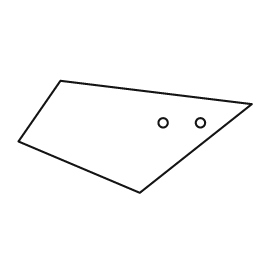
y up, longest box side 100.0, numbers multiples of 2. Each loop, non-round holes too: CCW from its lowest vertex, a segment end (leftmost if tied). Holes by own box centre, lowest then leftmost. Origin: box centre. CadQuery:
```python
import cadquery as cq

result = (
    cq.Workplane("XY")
    .moveTo(2.0, -24.0)
    .lineTo(50.0, 14.0)
    .lineTo(-32.0, 24.0)
    .lineTo(-50.0, -2.0)
    .close()
    .moveTo(12.0, 6.0)
    .circle(2.0)
    .moveTo(28.0, 6.0)
    .circle(2.0)
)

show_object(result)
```